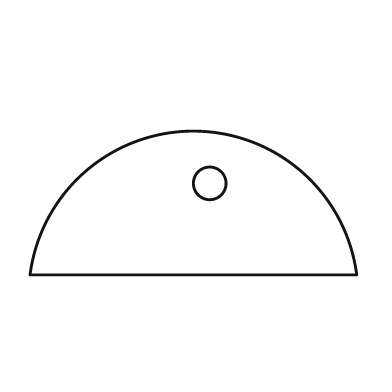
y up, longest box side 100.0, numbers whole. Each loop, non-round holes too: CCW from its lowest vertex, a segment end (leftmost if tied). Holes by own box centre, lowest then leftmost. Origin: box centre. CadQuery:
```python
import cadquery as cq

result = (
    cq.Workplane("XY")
    .moveTo(-50.0, -22.0)
    .lineTo(50.0, -22.0)
    .threePointArc((0.0, 22.0), (-50.0, -22.0))
    .close()
    .moveTo(5.0, 6.0)
    .circle(5.0)
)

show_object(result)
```